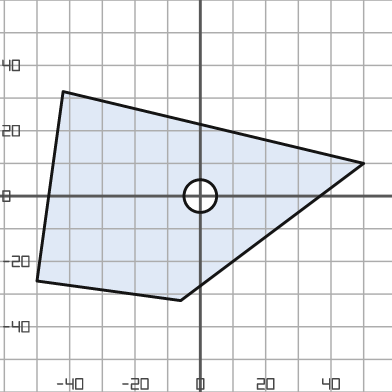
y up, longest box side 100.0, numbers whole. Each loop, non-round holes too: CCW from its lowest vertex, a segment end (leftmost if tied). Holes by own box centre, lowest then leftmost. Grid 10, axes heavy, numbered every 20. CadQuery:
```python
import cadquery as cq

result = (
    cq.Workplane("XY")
    .moveTo(-6.0, -32.0)
    .lineTo(50.0, 10.0)
    .lineTo(-42.0, 32.0)
    .lineTo(-50.0, -26.0)
    .close()
    .moveTo(0.0, 0.0)
    .circle(5.0)
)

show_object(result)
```